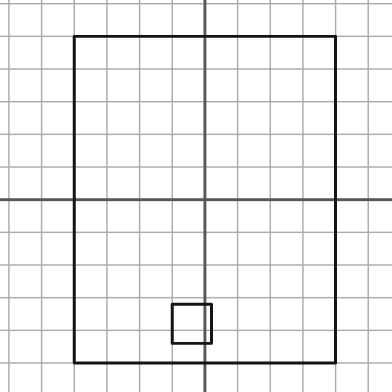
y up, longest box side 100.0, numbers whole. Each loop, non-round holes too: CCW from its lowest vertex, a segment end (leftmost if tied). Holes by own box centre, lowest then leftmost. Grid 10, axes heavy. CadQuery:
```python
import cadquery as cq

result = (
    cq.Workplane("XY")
    .moveTo(-40.0, -50.0)
    .lineTo(40.0, -50.0)
    .lineTo(40.0, 50.0)
    .lineTo(-40.0, 50.0)
    .close()
    .moveTo(-10.0, -44.0)
    .lineTo(2.0, -44.0)
    .lineTo(2.0, -32.0)
    .lineTo(-10.0, -32.0)
    .close()
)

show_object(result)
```